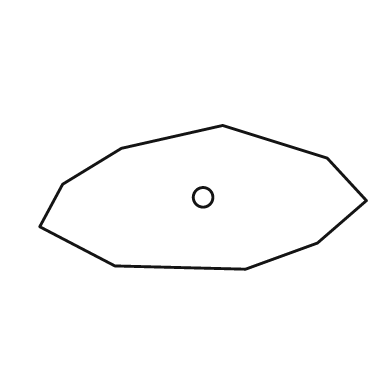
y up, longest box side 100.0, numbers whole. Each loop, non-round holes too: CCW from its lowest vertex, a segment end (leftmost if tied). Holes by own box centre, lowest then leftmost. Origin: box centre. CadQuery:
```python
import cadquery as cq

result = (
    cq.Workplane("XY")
    .moveTo(13.0, -22.0)
    .lineTo(35.0, -14.0)
    .lineTo(50.0, -1.0)
    .lineTo(38.0, 12.0)
    .lineTo(6.0, 22.0)
    .lineTo(-25.0, 15.0)
    .lineTo(-43.0, 4.0)
    .lineTo(-50.0, -9.0)
    .lineTo(-27.0, -21.0)
    .close()
    .moveTo(0.0, 0.0)
    .circle(3.0)
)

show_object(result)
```